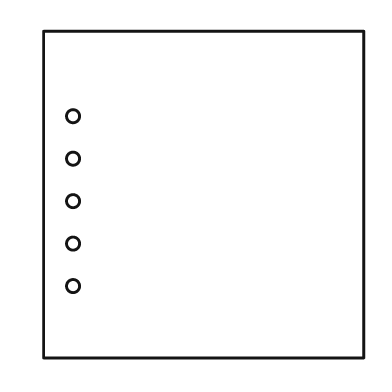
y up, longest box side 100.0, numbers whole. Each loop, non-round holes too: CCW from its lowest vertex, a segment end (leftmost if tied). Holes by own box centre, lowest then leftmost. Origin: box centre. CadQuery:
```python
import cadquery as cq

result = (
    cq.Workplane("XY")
    .moveTo(-49.0, -50.0)
    .lineTo(49.0, -50.0)
    .lineTo(49.0, 50.0)
    .lineTo(-49.0, 50.0)
    .close()
    .moveTo(-40.0, -28.0)
    .circle(2.0)
    .moveTo(-40.0, -15.0)
    .circle(2.0)
    .moveTo(-40.0, -2.0)
    .circle(2.0)
    .moveTo(-40.0, 11.0)
    .circle(2.0)
    .moveTo(-40.0, 24.0)
    .circle(2.0)
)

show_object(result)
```